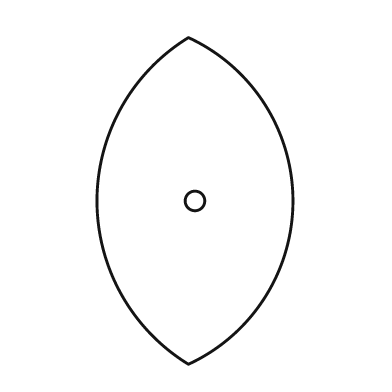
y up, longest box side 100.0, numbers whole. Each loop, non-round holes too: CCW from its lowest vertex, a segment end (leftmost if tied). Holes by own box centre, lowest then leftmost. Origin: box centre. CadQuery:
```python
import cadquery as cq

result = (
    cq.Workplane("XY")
    .moveTo(-2.0, -50.0)
    .threePointArc((30.0, 0.0), (-2.0, 50.0))
    .threePointArc((-30.0, 0.0), (-2.0, -50.0))
    .close()
    .moveTo(0.0, 0.0)
    .circle(3.0)
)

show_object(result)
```